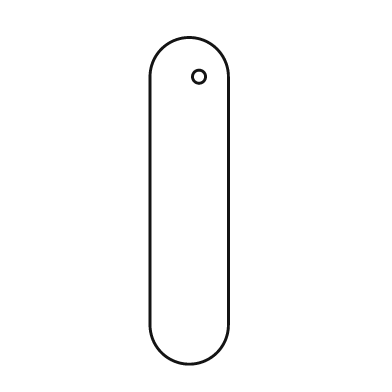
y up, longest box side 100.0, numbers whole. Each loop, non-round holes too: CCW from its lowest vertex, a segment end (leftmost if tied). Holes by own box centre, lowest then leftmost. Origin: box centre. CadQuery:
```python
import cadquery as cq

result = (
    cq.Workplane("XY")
    .moveTo(-12.0, -38.0)
    .threePointArc((0.0, -50.0), (12.0, -38.0))
    .lineTo(12.0, 38.0)
    .threePointArc((0.0, 50.0), (-12.0, 38.0))
    .close()
    .moveTo(3.0, 38.0)
    .circle(2.0)
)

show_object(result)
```